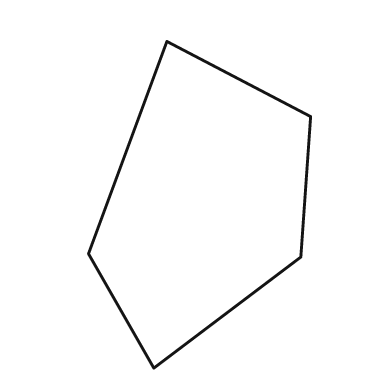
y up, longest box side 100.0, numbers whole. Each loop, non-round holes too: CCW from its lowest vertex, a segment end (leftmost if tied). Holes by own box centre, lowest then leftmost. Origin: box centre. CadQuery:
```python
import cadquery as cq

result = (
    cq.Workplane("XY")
    .moveTo(-14.0, -50.0)
    .lineTo(31.0, -16.0)
    .lineTo(34.0, 27.0)
    .lineTo(-10.0, 50.0)
    .lineTo(-34.0, -15.0)
    .close()
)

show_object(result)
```